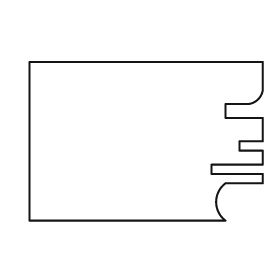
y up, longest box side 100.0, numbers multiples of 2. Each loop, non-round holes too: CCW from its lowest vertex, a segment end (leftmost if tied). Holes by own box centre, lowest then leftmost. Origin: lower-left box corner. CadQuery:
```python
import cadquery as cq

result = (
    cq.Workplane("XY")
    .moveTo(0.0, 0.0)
    .lineTo(84.0, 0.0)
    .threePointArc((80.0, 8.0), (84.0, 16.0))
    .lineTo(100.0, 16.0)
    .lineTo(100.0, 20.0)
    .lineTo(78.0, 20.0)
    .lineTo(78.0, 24.0)
    .lineTo(100.0, 24.0)
    .lineTo(100.0, 30.0)
    .lineTo(90.0, 30.0)
    .lineTo(90.0, 34.0)
    .lineTo(100.0, 34.0)
    .lineTo(100.0, 44.0)
    .lineTo(84.0, 44.0)
    .lineTo(84.0, 50.0)
    .lineTo(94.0, 50.0)
    .threePointArc((98.0, 52.0), (100.0, 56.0))
    .lineTo(100.0, 68.0)
    .lineTo(0.0, 68.0)
    .close()
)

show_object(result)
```